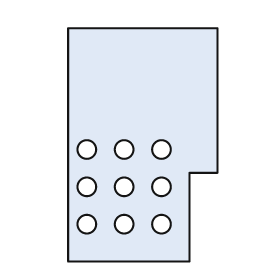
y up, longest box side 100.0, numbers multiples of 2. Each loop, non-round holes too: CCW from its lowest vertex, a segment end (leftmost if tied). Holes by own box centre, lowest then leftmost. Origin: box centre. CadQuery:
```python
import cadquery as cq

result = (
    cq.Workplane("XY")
    .moveTo(-32.0, -50.0)
    .lineTo(20.0, -50.0)
    .lineTo(20.0, -12.0)
    .lineTo(32.0, -12.0)
    .lineTo(32.0, 50.0)
    .lineTo(-32.0, 50.0)
    .close()
    .moveTo(-24.0, -34.0)
    .circle(4.0)
    .moveTo(-8.0, -34.0)
    .circle(4.0)
    .moveTo(8.0, -34.0)
    .circle(4.0)
    .moveTo(-24.0, -18.0)
    .circle(4.0)
    .moveTo(-8.0, -18.0)
    .circle(4.0)
    .moveTo(8.0, -18.0)
    .circle(4.0)
    .moveTo(-24.0, -2.0)
    .circle(4.0)
    .moveTo(-8.0, -2.0)
    .circle(4.0)
    .moveTo(8.0, -2.0)
    .circle(4.0)
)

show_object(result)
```